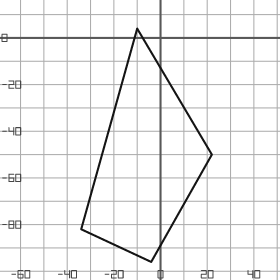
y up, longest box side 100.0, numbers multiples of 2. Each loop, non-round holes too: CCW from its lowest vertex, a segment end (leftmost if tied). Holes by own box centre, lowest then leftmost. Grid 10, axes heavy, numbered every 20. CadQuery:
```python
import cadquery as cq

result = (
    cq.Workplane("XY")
    .moveTo(-4.0, -96.0)
    .lineTo(22.0, -50.0)
    .lineTo(-10.0, 4.0)
    .lineTo(-34.0, -82.0)
    .close()
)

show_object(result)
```